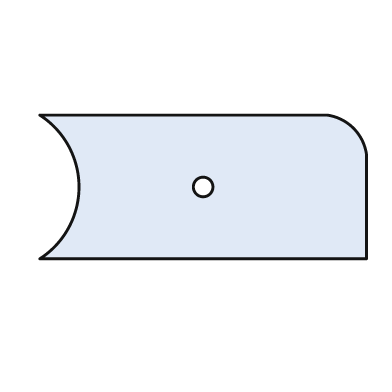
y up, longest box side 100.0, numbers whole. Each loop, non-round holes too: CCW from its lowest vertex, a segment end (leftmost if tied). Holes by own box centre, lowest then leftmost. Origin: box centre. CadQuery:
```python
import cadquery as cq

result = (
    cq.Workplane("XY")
    .moveTo(-50.0, -22.0)
    .lineTo(50.0, -22.0)
    .lineTo(50.0, 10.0)
    .threePointArc((46.0, 18.0), (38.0, 22.0))
    .lineTo(-50.0, 22.0)
    .threePointArc((-38.0, 0.0), (-50.0, -22.0))
    .close()
    .moveTo(0.0, 0.0)
    .circle(3.0)
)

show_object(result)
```